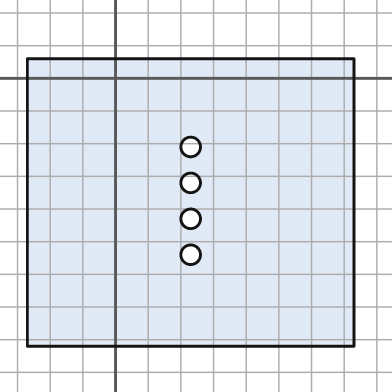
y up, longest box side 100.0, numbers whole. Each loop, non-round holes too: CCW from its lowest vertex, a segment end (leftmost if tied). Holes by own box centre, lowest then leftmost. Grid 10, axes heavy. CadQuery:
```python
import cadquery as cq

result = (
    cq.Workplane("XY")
    .moveTo(-27.0, -82.0)
    .lineTo(73.0, -82.0)
    .lineTo(73.0, 6.0)
    .lineTo(-27.0, 6.0)
    .close()
    .moveTo(23.0, -54.0)
    .circle(3.0)
    .moveTo(23.0, -43.0)
    .circle(3.0)
    .moveTo(23.0, -32.0)
    .circle(3.0)
    .moveTo(23.0, -21.0)
    .circle(3.0)
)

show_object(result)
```